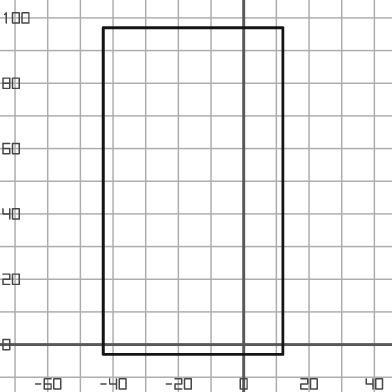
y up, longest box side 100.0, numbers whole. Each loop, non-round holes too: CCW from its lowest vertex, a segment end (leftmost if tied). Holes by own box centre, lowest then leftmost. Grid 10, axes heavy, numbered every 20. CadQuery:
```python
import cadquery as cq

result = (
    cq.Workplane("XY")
    .moveTo(-43.0, -3.0)
    .lineTo(12.0, -3.0)
    .lineTo(12.0, 97.0)
    .lineTo(-43.0, 97.0)
    .close()
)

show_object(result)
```